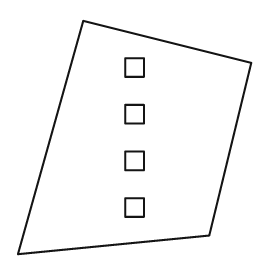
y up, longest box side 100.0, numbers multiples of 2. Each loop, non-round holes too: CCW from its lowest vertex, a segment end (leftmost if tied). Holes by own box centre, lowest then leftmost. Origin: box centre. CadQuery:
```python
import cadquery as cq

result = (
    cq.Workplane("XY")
    .moveTo(-50.0, -50.0)
    .lineTo(32.0, -42.0)
    .lineTo(50.0, 32.0)
    .lineTo(-22.0, 50.0)
    .close()
    .moveTo(-4.0, -34.0)
    .lineTo(4.0, -34.0)
    .lineTo(4.0, -26.0)
    .lineTo(-4.0, -26.0)
    .close()
    .moveTo(-4.0, -14.0)
    .lineTo(4.0, -14.0)
    .lineTo(4.0, -6.0)
    .lineTo(-4.0, -6.0)
    .close()
    .moveTo(-4.0, 6.0)
    .lineTo(4.0, 6.0)
    .lineTo(4.0, 14.0)
    .lineTo(-4.0, 14.0)
    .close()
    .moveTo(-4.0, 26.0)
    .lineTo(4.0, 26.0)
    .lineTo(4.0, 34.0)
    .lineTo(-4.0, 34.0)
    .close()
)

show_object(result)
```